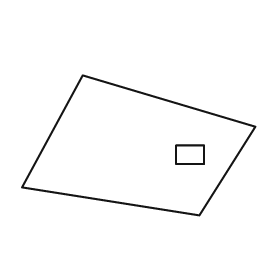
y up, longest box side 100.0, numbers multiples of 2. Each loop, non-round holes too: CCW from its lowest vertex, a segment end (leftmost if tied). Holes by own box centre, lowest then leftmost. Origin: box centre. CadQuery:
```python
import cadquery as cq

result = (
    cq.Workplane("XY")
    .moveTo(26.0, -30.0)
    .lineTo(50.0, 8.0)
    .lineTo(-24.0, 30.0)
    .lineTo(-50.0, -18.0)
    .close()
    .moveTo(16.0, -8.0)
    .lineTo(28.0, -8.0)
    .lineTo(28.0, 0.0)
    .lineTo(16.0, 0.0)
    .close()
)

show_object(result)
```